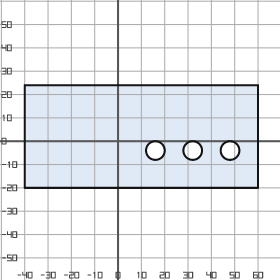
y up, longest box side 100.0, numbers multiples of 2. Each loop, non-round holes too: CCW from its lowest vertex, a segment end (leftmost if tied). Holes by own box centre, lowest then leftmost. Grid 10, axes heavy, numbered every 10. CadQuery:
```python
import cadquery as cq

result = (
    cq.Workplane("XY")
    .moveTo(-40.0, -20.0)
    .lineTo(60.0, -20.0)
    .lineTo(60.0, 24.0)
    .lineTo(-40.0, 24.0)
    .close()
    .moveTo(16.0, -4.0)
    .circle(4.0)
    .moveTo(32.0, -4.0)
    .circle(4.0)
    .moveTo(48.0, -4.0)
    .circle(4.0)
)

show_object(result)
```